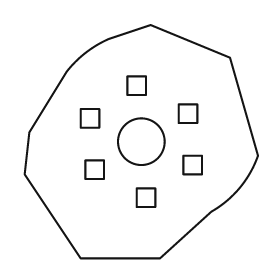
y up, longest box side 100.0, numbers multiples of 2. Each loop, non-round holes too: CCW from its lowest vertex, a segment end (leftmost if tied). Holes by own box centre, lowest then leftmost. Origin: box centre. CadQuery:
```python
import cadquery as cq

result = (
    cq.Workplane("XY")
    .moveTo(-26.0, -50.0)
    .lineTo(8.0, -50.0)
    .lineTo(30.0, -30.0)
    .threePointArc((42.0, -20.0), (50.0, -6.0))
    .lineTo(38.0, 36.0)
    .lineTo(4.0, 50.0)
    .lineTo(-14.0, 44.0)
    .threePointArc((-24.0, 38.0), (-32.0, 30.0))
    .lineTo(-48.0, 4.0)
    .lineTo(-50.0, -14.0)
    .close()
    .moveTo(-2.0, -28.0)
    .lineTo(6.0, -28.0)
    .lineTo(6.0, -20.0)
    .lineTo(-2.0, -20.0)
    .close()
    .moveTo(-24.0, -16.0)
    .lineTo(-16.0, -16.0)
    .lineTo(-16.0, -8.0)
    .lineTo(-24.0, -8.0)
    .close()
    .moveTo(18.0, -14.0)
    .lineTo(26.0, -14.0)
    .lineTo(26.0, -6.0)
    .lineTo(18.0, -6.0)
    .close()
    .moveTo(0.0, 0.0)
    .circle(10.0)
    .moveTo(-26.0, 6.0)
    .lineTo(-18.0, 6.0)
    .lineTo(-18.0, 14.0)
    .lineTo(-26.0, 14.0)
    .close()
    .moveTo(16.0, 8.0)
    .lineTo(24.0, 8.0)
    .lineTo(24.0, 16.0)
    .lineTo(16.0, 16.0)
    .close()
    .moveTo(-6.0, 20.0)
    .lineTo(2.0, 20.0)
    .lineTo(2.0, 28.0)
    .lineTo(-6.0, 28.0)
    .close()
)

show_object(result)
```